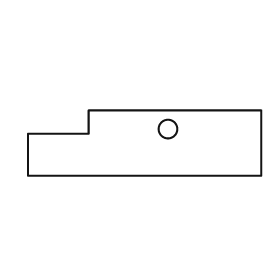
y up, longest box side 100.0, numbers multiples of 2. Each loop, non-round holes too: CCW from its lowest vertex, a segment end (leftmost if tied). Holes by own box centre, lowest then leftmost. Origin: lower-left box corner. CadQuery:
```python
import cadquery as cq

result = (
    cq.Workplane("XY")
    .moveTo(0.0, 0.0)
    .lineTo(100.0, 0.0)
    .lineTo(100.0, 28.0)
    .lineTo(26.0, 28.0)
    .lineTo(26.0, 18.0)
    .lineTo(0.0, 18.0)
    .close()
    .moveTo(60.0, 20.0)
    .circle(4.0)
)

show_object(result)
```